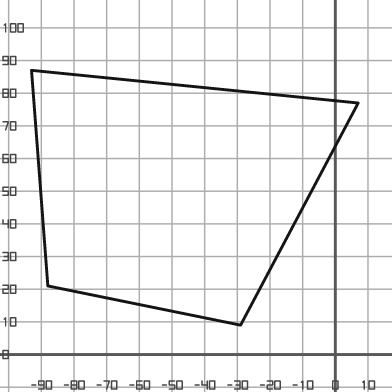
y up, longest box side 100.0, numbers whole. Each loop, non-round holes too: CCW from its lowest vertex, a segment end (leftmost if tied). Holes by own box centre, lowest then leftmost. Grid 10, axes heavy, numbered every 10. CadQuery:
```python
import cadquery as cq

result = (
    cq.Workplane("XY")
    .moveTo(-29.0, 9.0)
    .lineTo(7.0, 77.0)
    .lineTo(-93.0, 87.0)
    .lineTo(-88.0, 21.0)
    .close()
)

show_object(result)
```